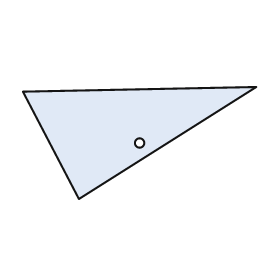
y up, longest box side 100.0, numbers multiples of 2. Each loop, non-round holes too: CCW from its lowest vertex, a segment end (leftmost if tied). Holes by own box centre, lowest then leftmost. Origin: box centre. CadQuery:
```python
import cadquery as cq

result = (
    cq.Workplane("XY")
    .moveTo(-26.0, -24.0)
    .lineTo(50.0, 24.0)
    .lineTo(-50.0, 22.0)
    .close()
    .moveTo(0.0, 0.0)
    .circle(2.0)
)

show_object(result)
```